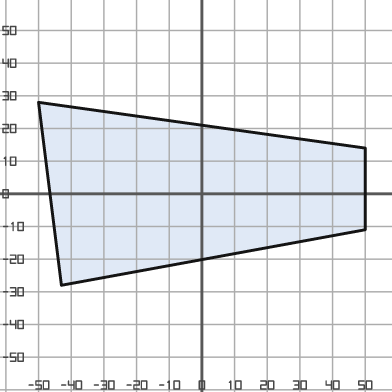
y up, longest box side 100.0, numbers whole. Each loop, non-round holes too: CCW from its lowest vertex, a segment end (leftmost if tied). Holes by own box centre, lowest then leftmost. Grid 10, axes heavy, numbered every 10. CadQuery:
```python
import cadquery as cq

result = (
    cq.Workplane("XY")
    .moveTo(-43.0, -28.0)
    .lineTo(50.0, -11.0)
    .lineTo(50.0, 14.0)
    .lineTo(-50.0, 28.0)
    .close()
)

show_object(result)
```